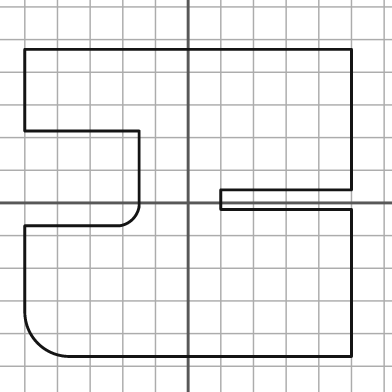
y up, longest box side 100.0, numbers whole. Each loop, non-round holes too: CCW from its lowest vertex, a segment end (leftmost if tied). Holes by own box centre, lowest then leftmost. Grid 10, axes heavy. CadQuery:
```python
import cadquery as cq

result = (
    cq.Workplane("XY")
    .moveTo(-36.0, -47.0)
    .lineTo(50.0, -47.0)
    .lineTo(50.0, -2.0)
    .lineTo(10.0, -2.0)
    .lineTo(10.0, 4.0)
    .lineTo(50.0, 4.0)
    .lineTo(50.0, 47.0)
    .lineTo(-50.0, 47.0)
    .lineTo(-50.0, 22.0)
    .lineTo(-15.0, 22.0)
    .lineTo(-15.0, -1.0)
    .threePointArc((-17.0, -5.0), (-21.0, -7.0))
    .lineTo(-50.0, -7.0)
    .lineTo(-50.0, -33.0)
    .threePointArc((-46.0, -43.0), (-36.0, -47.0))
    .close()
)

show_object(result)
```